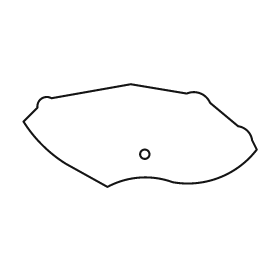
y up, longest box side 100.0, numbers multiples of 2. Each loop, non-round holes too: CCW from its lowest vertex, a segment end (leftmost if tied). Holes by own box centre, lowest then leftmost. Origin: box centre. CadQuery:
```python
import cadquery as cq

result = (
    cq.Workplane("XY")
    .moveTo(-14.0, -22.0)
    .threePointArc((0.0, -18.0), (14.0, -20.0))
    .threePointArc((34.0, -18.0), (50.0, -6.0))
    .lineTo(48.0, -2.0)
    .threePointArc((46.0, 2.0), (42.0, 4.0))
    .lineTo(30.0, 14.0)
    .threePointArc((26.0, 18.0), (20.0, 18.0))
    .lineTo(-4.0, 22.0)
    .lineTo(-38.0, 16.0)
    .threePointArc((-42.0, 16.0), (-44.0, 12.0))
    .lineTo(-50.0, 6.0)
    .threePointArc((-42.0, -4.0), (-32.0, -12.0))
    .close()
    .moveTo(2.0, -8.0)
    .circle(2.0)
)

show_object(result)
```